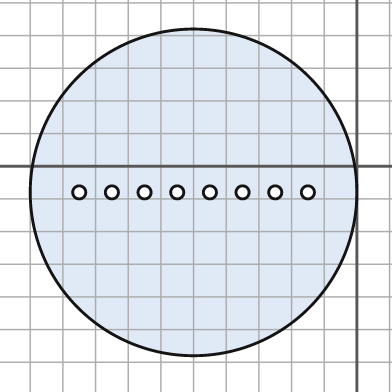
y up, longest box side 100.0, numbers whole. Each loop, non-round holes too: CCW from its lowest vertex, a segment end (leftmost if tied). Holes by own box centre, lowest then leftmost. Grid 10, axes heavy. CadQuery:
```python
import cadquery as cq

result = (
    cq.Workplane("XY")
    .moveTo(-50.0, -8.0)
    .circle(50.0)
    .moveTo(-85.0, -8.0)
    .circle(2.0)
    .moveTo(-75.0, -8.0)
    .circle(2.0)
    .moveTo(-65.0, -8.0)
    .circle(2.0)
    .moveTo(-55.0, -8.0)
    .circle(2.0)
    .moveTo(-45.0, -8.0)
    .circle(2.0)
    .moveTo(-35.0, -8.0)
    .circle(2.0)
    .moveTo(-25.0, -8.0)
    .circle(2.0)
    .moveTo(-15.0, -8.0)
    .circle(2.0)
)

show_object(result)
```